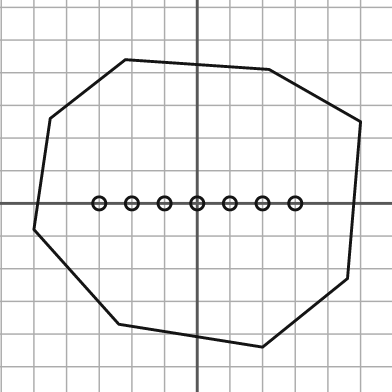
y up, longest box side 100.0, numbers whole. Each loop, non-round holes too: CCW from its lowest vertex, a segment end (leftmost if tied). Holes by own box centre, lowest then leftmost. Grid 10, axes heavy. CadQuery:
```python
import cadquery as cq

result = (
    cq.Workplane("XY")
    .moveTo(20.0, -44.0)
    .lineTo(46.0, -23.0)
    .lineTo(50.0, 25.0)
    .lineTo(22.0, 41.0)
    .lineTo(-22.0, 44.0)
    .lineTo(-45.0, 26.0)
    .lineTo(-50.0, -8.0)
    .lineTo(-24.0, -37.0)
    .close()
    .moveTo(-30.0, 0.0)
    .circle(2.0)
    .moveTo(-20.0, 0.0)
    .circle(2.0)
    .moveTo(-10.0, 0.0)
    .circle(2.0)
    .moveTo(0.0, 0.0)
    .circle(2.0)
    .moveTo(10.0, 0.0)
    .circle(2.0)
    .moveTo(20.0, 0.0)
    .circle(2.0)
    .moveTo(30.0, 0.0)
    .circle(2.0)
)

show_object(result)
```